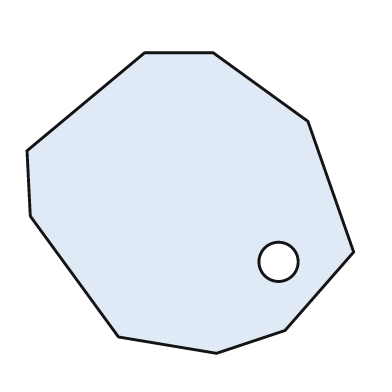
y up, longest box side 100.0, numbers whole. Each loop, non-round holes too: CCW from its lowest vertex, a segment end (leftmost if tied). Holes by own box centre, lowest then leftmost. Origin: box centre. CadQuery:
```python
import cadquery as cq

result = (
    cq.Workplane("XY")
    .moveTo(8.0, -46.0)
    .lineTo(29.0, -39.0)
    .lineTo(50.0, -15.0)
    .lineTo(36.0, 25.0)
    .lineTo(7.0, 46.0)
    .lineTo(-14.0, 46.0)
    .lineTo(-50.0, 16.0)
    .lineTo(-49.0, -4.0)
    .lineTo(-22.0, -41.0)
    .close()
    .moveTo(27.0, -18.0)
    .circle(6.0)
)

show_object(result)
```